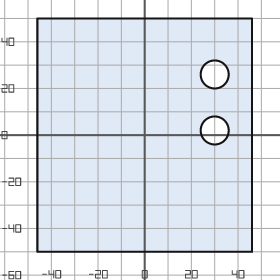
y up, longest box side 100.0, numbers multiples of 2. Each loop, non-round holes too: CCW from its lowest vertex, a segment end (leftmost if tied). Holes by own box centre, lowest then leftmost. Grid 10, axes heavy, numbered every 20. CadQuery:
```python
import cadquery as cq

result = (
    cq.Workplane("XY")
    .moveTo(-46.0, -50.0)
    .lineTo(46.0, -50.0)
    .lineTo(46.0, 50.0)
    .lineTo(-46.0, 50.0)
    .close()
    .moveTo(30.0, 2.0)
    .circle(6.0)
    .moveTo(30.0, 26.0)
    .circle(6.0)
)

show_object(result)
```